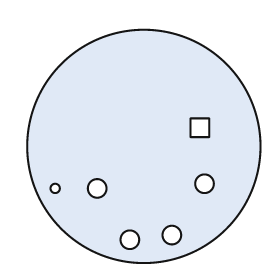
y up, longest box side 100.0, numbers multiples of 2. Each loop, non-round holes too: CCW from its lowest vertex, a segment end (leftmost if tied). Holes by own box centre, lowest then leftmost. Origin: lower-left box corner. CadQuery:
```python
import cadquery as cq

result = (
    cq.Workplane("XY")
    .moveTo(50.0, 50.0)
    .circle(50.0)
    .moveTo(44.0, 10.0)
    .circle(4.0)
    .moveTo(62.0, 12.0)
    .circle(4.0)
    .moveTo(12.0, 32.0)
    .circle(2.0)
    .moveTo(30.0, 32.0)
    .circle(4.0)
    .moveTo(76.0, 34.0)
    .circle(4.0)
    .moveTo(70.0, 54.0)
    .lineTo(78.0, 54.0)
    .lineTo(78.0, 62.0)
    .lineTo(70.0, 62.0)
    .close()
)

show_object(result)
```